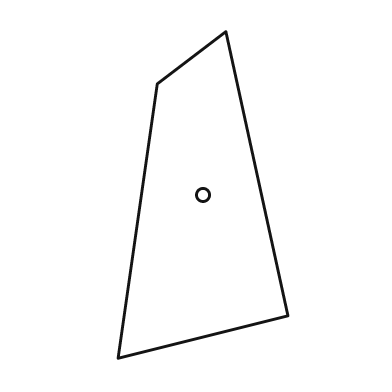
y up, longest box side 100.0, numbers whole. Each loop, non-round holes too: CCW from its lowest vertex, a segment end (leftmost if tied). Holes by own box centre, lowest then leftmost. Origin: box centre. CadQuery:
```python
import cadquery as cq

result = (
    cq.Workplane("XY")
    .moveTo(-26.0, -50.0)
    .lineTo(26.0, -37.0)
    .lineTo(7.0, 50.0)
    .lineTo(-14.0, 34.0)
    .close()
    .moveTo(0.0, 0.0)
    .circle(2.0)
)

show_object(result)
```